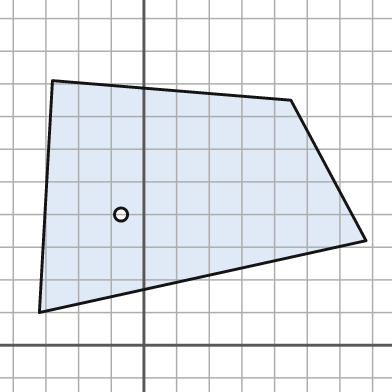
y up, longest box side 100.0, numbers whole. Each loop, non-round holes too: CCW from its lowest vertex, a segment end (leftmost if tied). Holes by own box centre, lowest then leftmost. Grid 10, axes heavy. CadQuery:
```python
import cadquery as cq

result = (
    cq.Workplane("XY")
    .moveTo(-32.0, 10.0)
    .lineTo(68.0, 32.0)
    .lineTo(45.0, 75.0)
    .lineTo(-28.0, 81.0)
    .close()
    .moveTo(-7.0, 40.0)
    .circle(2.0)
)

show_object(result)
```